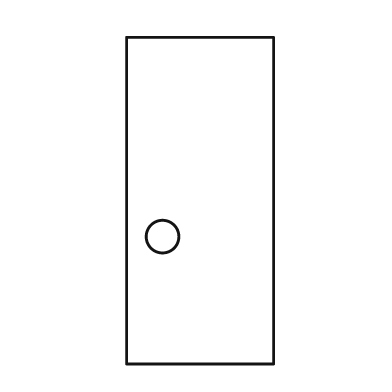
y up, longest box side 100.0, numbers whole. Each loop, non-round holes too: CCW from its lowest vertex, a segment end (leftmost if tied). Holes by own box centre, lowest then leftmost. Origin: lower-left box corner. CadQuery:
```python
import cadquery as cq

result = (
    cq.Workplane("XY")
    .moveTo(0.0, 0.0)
    .lineTo(45.0, 0.0)
    .lineTo(45.0, 100.0)
    .lineTo(0.0, 100.0)
    .close()
    .moveTo(11.0, 39.0)
    .circle(5.0)
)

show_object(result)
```